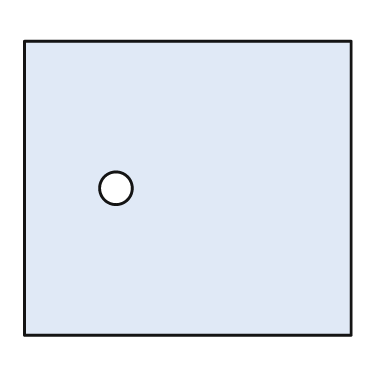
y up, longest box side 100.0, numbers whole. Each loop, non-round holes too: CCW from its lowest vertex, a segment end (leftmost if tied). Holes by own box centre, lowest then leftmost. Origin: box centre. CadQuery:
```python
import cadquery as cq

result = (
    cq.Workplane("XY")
    .moveTo(-50.0, -45.0)
    .lineTo(50.0, -45.0)
    .lineTo(50.0, 45.0)
    .lineTo(-50.0, 45.0)
    .close()
    .moveTo(-22.0, 0.0)
    .circle(5.0)
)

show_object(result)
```